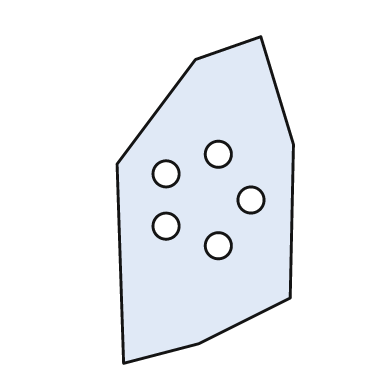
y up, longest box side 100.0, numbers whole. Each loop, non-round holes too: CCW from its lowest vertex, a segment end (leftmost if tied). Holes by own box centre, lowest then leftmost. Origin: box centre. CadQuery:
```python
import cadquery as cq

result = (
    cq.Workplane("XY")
    .moveTo(-25.0, -50.0)
    .lineTo(-2.0, -44.0)
    .lineTo(26.0, -30.0)
    .lineTo(27.0, 17.0)
    .lineTo(17.0, 50.0)
    .lineTo(-3.0, 43.0)
    .lineTo(-27.0, 11.0)
    .close()
    .moveTo(4.0, -14.0)
    .circle(4.0)
    .moveTo(-12.0, -8.0)
    .circle(4.0)
    .moveTo(14.0, 0.0)
    .circle(4.0)
    .moveTo(-12.0, 8.0)
    .circle(4.0)
    .moveTo(4.0, 14.0)
    .circle(4.0)
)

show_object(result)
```